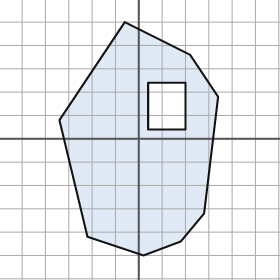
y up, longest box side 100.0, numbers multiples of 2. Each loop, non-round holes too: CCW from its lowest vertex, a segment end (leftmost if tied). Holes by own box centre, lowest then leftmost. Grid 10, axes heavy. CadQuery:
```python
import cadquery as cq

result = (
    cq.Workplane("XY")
    .moveTo(2.0, -50.0)
    .lineTo(18.0, -44.0)
    .lineTo(28.0, -32.0)
    .lineTo(34.0, 18.0)
    .lineTo(22.0, 36.0)
    .lineTo(-6.0, 50.0)
    .lineTo(-34.0, 8.0)
    .lineTo(-22.0, -42.0)
    .close()
    .moveTo(4.0, 4.0)
    .lineTo(20.0, 4.0)
    .lineTo(20.0, 24.0)
    .lineTo(4.0, 24.0)
    .close()
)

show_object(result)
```